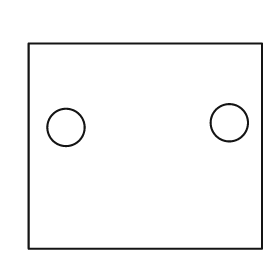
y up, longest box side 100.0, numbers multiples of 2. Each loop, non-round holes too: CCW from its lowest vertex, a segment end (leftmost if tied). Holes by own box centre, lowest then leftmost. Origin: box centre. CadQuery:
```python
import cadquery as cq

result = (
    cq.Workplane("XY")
    .moveTo(-50.0, -44.0)
    .lineTo(50.0, -44.0)
    .lineTo(50.0, 44.0)
    .lineTo(-50.0, 44.0)
    .close()
    .moveTo(-34.0, 8.0)
    .circle(8.0)
    .moveTo(36.0, 10.0)
    .circle(8.0)
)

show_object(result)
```